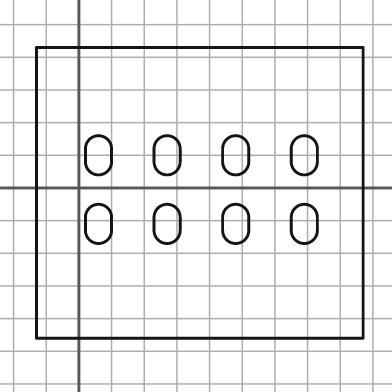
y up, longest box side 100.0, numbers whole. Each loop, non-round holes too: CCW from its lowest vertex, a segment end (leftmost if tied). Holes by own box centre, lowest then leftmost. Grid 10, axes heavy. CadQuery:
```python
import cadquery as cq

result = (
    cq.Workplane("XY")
    .moveTo(-13.0, -46.0)
    .lineTo(87.0, -46.0)
    .lineTo(87.0, 43.0)
    .lineTo(-13.0, 43.0)
    .close()
    .moveTo(2.0, -13.0)
    .threePointArc((6.0, -17.0), (10.0, -13.0))
    .lineTo(10.0, -9.0)
    .threePointArc((6.0, -5.0), (2.0, -9.0))
    .close()
    .moveTo(23.0, -13.0)
    .threePointArc((27.0, -17.0), (31.0, -13.0))
    .lineTo(31.0, -9.0)
    .threePointArc((27.0, -5.0), (23.0, -9.0))
    .close()
    .moveTo(44.0, -13.0)
    .threePointArc((48.0, -17.0), (52.0, -13.0))
    .lineTo(52.0, -9.0)
    .threePointArc((48.0, -5.0), (44.0, -9.0))
    .close()
    .moveTo(65.0, -13.0)
    .threePointArc((69.0, -17.0), (73.0, -13.0))
    .lineTo(73.0, -9.0)
    .threePointArc((69.0, -5.0), (65.0, -9.0))
    .close()
    .moveTo(2.0, 8.0)
    .threePointArc((6.0, 4.0), (10.0, 8.0))
    .lineTo(10.0, 12.0)
    .threePointArc((6.0, 16.0), (2.0, 12.0))
    .close()
    .moveTo(23.0, 8.0)
    .threePointArc((27.0, 4.0), (31.0, 8.0))
    .lineTo(31.0, 12.0)
    .threePointArc((27.0, 16.0), (23.0, 12.0))
    .close()
    .moveTo(44.0, 8.0)
    .threePointArc((48.0, 4.0), (52.0, 8.0))
    .lineTo(52.0, 12.0)
    .threePointArc((48.0, 16.0), (44.0, 12.0))
    .close()
    .moveTo(65.0, 8.0)
    .threePointArc((69.0, 4.0), (73.0, 8.0))
    .lineTo(73.0, 12.0)
    .threePointArc((69.0, 16.0), (65.0, 12.0))
    .close()
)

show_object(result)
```